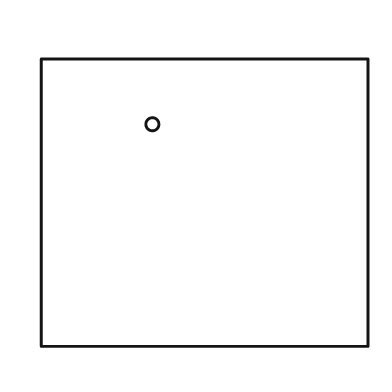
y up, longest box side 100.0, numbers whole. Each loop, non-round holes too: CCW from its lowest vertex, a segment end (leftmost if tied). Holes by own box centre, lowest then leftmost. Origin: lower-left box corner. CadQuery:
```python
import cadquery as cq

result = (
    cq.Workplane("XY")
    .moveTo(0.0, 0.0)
    .lineTo(100.0, 0.0)
    .lineTo(100.0, 88.0)
    .lineTo(0.0, 88.0)
    .close()
    .moveTo(34.0, 68.0)
    .circle(2.0)
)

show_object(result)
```